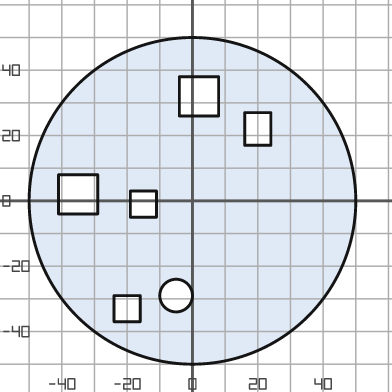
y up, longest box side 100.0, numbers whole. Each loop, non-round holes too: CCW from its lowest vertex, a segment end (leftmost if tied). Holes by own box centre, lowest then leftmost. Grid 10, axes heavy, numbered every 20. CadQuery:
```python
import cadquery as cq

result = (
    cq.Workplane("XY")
    .moveTo(0.0, 0.0)
    .circle(50.0)
    .moveTo(-24.0, -37.0)
    .lineTo(-16.0, -37.0)
    .lineTo(-16.0, -29.0)
    .lineTo(-24.0, -29.0)
    .close()
    .moveTo(-5.0, -29.0)
    .circle(5.0)
    .moveTo(-19.0, -5.0)
    .lineTo(-11.0, -5.0)
    .lineTo(-11.0, 3.0)
    .lineTo(-19.0, 3.0)
    .close()
    .moveTo(-41.0, -4.0)
    .lineTo(-29.0, -4.0)
    .lineTo(-29.0, 8.0)
    .lineTo(-41.0, 8.0)
    .close()
    .moveTo(16.0, 17.0)
    .lineTo(24.0, 17.0)
    .lineTo(24.0, 27.0)
    .lineTo(16.0, 27.0)
    .close()
    .moveTo(-4.0, 26.0)
    .lineTo(8.0, 26.0)
    .lineTo(8.0, 38.0)
    .lineTo(-4.0, 38.0)
    .close()
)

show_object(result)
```